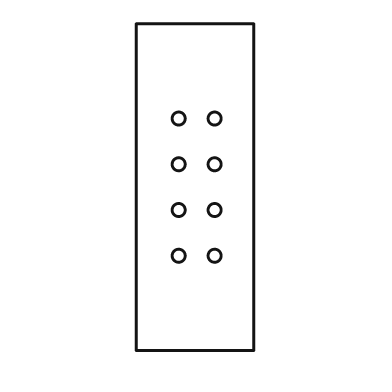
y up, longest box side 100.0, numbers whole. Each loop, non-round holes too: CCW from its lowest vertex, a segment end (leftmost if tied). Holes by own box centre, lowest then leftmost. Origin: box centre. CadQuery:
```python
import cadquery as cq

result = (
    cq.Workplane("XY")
    .moveTo(-18.0, -50.0)
    .lineTo(18.0, -50.0)
    .lineTo(18.0, 50.0)
    .lineTo(-18.0, 50.0)
    .close()
    .moveTo(-5.0, -21.0)
    .circle(2.0)
    .moveTo(6.0, -21.0)
    .circle(2.0)
    .moveTo(-5.0, -7.0)
    .circle(2.0)
    .moveTo(6.0, -7.0)
    .circle(2.0)
    .moveTo(-5.0, 7.0)
    .circle(2.0)
    .moveTo(6.0, 7.0)
    .circle(2.0)
    .moveTo(-5.0, 21.0)
    .circle(2.0)
    .moveTo(6.0, 21.0)
    .circle(2.0)
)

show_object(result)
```